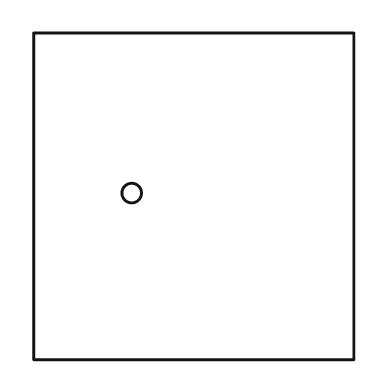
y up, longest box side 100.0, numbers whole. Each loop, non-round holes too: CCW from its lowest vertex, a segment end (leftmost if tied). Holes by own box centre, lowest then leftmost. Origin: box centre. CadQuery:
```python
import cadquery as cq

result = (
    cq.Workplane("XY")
    .moveTo(-49.0, -50.0)
    .lineTo(49.0, -50.0)
    .lineTo(49.0, 50.0)
    .lineTo(-49.0, 50.0)
    .close()
    .moveTo(-19.0, 1.0)
    .circle(3.0)
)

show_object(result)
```